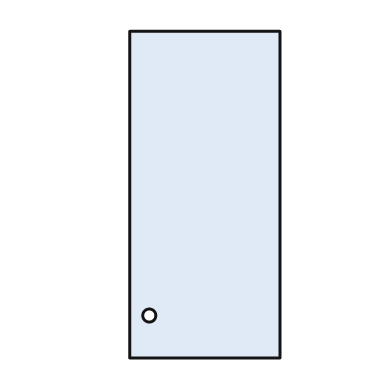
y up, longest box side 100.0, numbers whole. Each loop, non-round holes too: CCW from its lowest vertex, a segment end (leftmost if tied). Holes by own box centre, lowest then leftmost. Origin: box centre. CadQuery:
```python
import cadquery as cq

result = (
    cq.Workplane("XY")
    .moveTo(-23.0, -50.0)
    .lineTo(23.0, -50.0)
    .lineTo(23.0, 50.0)
    .lineTo(-23.0, 50.0)
    .close()
    .moveTo(-17.0, -37.0)
    .circle(2.0)
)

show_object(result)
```